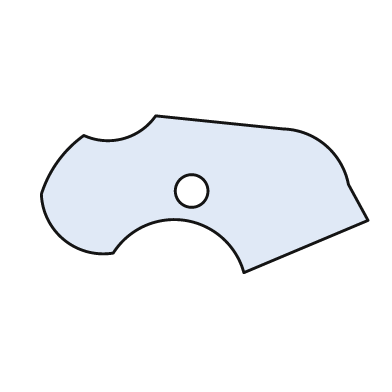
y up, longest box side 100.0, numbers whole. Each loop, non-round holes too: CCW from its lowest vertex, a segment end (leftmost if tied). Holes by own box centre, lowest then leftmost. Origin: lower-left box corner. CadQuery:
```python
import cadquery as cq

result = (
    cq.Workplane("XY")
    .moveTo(62.0, 0.0)
    .lineTo(100.0, 16.0)
    .lineTo(94.0, 27.0)
    .threePointArc((87.0, 39.0), (74.0, 44.0))
    .lineTo(35.0, 48.0)
    .threePointArc((25.0, 41.0), (13.0, 42.0))
    .threePointArc((5.0, 34.0), (0.0, 24.0))
    .threePointArc((7.0, 10.0), (22.0, 6.0))
    .threePointArc((44.0, 16.0), (62.0, 0.0))
    .close()
    .moveTo(46.0, 25.0)
    .circle(5.0)
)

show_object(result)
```